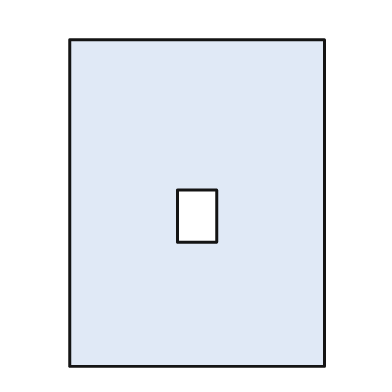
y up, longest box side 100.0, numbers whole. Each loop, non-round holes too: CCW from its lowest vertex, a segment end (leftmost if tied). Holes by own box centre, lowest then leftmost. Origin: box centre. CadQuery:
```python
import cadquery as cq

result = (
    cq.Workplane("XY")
    .moveTo(-39.0, -50.0)
    .lineTo(39.0, -50.0)
    .lineTo(39.0, 50.0)
    .lineTo(-39.0, 50.0)
    .close()
    .moveTo(-6.0, -12.0)
    .lineTo(6.0, -12.0)
    .lineTo(6.0, 4.0)
    .lineTo(-6.0, 4.0)
    .close()
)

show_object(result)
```